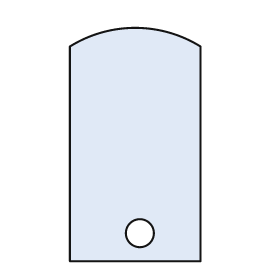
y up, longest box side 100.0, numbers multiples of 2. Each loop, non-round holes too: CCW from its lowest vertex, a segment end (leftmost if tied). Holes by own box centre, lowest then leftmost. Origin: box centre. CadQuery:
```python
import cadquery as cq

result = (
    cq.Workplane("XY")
    .moveTo(-28.0, -50.0)
    .lineTo(28.0, -50.0)
    .lineTo(28.0, 42.0)
    .threePointArc((0.0, 50.0), (-28.0, 42.0))
    .close()
    .moveTo(2.0, -38.0)
    .circle(6.0)
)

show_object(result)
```